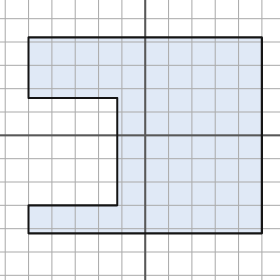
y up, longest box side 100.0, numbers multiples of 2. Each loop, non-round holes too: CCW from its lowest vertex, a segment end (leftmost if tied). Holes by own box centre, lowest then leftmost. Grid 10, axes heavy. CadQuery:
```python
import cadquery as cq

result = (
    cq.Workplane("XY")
    .moveTo(-50.0, -42.0)
    .lineTo(50.0, -42.0)
    .lineTo(50.0, 42.0)
    .lineTo(-50.0, 42.0)
    .lineTo(-50.0, 16.0)
    .lineTo(-12.0, 16.0)
    .lineTo(-12.0, -30.0)
    .lineTo(-50.0, -30.0)
    .close()
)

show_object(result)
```